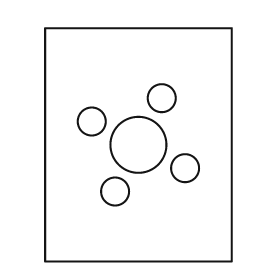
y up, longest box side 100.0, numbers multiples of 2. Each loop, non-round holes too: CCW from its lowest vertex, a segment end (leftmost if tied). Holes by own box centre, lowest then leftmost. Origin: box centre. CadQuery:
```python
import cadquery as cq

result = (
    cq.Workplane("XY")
    .moveTo(-40.0, -50.0)
    .lineTo(40.0, -50.0)
    .lineTo(40.0, 50.0)
    .lineTo(-40.0, 50.0)
    .close()
    .moveTo(-10.0, -20.0)
    .circle(6.0)
    .moveTo(20.0, -10.0)
    .circle(6.0)
    .moveTo(0.0, 0.0)
    .circle(12.0)
    .moveTo(-20.0, 10.0)
    .circle(6.0)
    .moveTo(10.0, 20.0)
    .circle(6.0)
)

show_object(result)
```